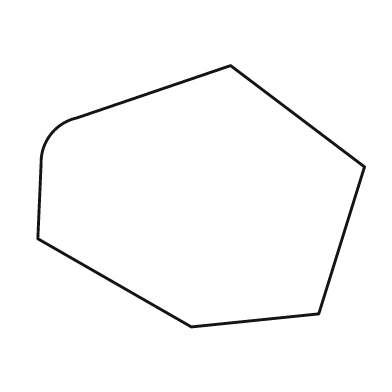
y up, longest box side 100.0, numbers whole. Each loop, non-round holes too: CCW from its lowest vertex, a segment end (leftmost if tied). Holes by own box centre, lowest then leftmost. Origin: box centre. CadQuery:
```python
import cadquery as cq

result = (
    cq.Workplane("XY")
    .moveTo(-3.0, -40.0)
    .lineTo(36.0, -36.0)
    .lineTo(50.0, 9.0)
    .lineTo(9.0, 40.0)
    .lineTo(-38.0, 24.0)
    .threePointArc((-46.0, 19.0), (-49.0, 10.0))
    .lineTo(-50.0, -13.0)
    .close()
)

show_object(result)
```